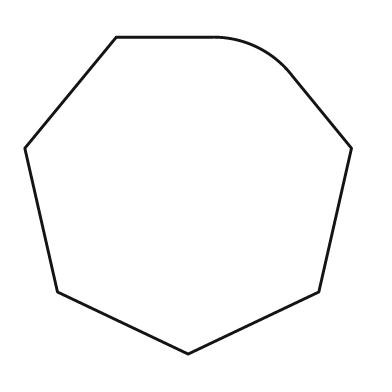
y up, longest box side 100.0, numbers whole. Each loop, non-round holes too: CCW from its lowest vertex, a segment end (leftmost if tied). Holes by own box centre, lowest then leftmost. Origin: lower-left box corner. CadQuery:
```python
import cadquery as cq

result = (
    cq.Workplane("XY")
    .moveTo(50.0, 0.0)
    .lineTo(90.0, 19.0)
    .lineTo(100.0, 63.0)
    .lineTo(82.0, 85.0)
    .threePointArc((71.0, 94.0), (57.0, 97.0))
    .lineTo(28.0, 97.0)
    .lineTo(0.0, 63.0)
    .lineTo(10.0, 19.0)
    .close()
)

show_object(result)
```